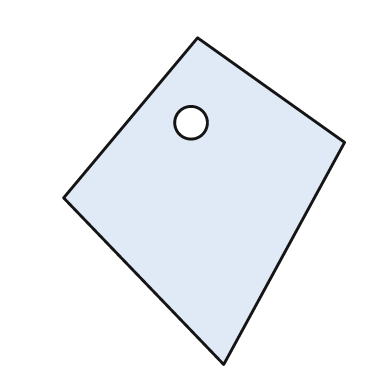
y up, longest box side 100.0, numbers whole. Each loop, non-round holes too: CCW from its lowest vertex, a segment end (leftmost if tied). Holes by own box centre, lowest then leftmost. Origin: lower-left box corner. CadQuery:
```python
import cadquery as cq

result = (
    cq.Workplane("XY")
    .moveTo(49.0, 0.0)
    .lineTo(86.0, 68.0)
    .lineTo(41.0, 100.0)
    .lineTo(0.0, 51.0)
    .close()
    .moveTo(39.0, 74.0)
    .circle(5.0)
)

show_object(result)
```